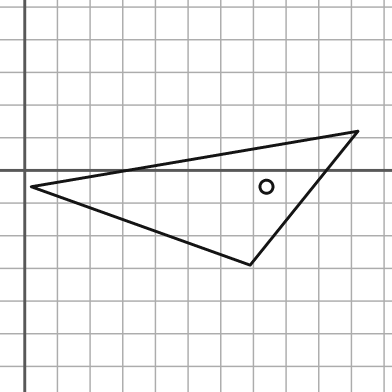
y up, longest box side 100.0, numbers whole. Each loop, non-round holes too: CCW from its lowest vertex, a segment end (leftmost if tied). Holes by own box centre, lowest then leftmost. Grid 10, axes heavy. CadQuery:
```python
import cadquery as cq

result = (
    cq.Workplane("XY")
    .moveTo(69.0, -29.0)
    .lineTo(102.0, 12.0)
    .lineTo(2.0, -5.0)
    .close()
    .moveTo(74.0, -5.0)
    .circle(2.0)
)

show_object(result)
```